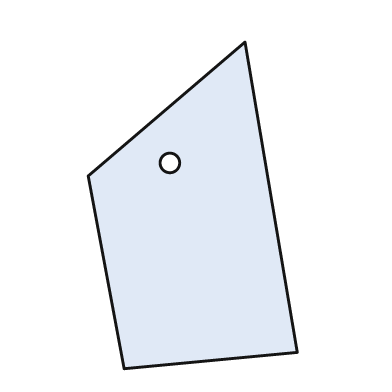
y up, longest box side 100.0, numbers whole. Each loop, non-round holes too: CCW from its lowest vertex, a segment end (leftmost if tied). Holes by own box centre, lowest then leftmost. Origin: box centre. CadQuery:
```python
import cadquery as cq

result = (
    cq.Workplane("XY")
    .moveTo(-21.0, -50.0)
    .lineTo(32.0, -45.0)
    .lineTo(16.0, 50.0)
    .lineTo(-32.0, 9.0)
    .close()
    .moveTo(-7.0, 13.0)
    .circle(3.0)
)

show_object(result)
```